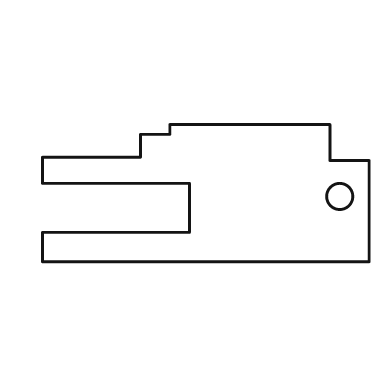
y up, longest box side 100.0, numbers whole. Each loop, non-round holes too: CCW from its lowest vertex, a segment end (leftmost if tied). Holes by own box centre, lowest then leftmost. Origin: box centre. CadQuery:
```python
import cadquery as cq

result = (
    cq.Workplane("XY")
    .moveTo(-50.0, -21.0)
    .lineTo(50.0, -21.0)
    .lineTo(50.0, 10.0)
    .lineTo(38.0, 10.0)
    .lineTo(38.0, 21.0)
    .lineTo(-11.0, 21.0)
    .lineTo(-11.0, 18.0)
    .lineTo(-20.0, 18.0)
    .lineTo(-20.0, 11.0)
    .lineTo(-50.0, 11.0)
    .lineTo(-50.0, 3.0)
    .lineTo(-5.0, 3.0)
    .lineTo(-5.0, -12.0)
    .lineTo(-50.0, -12.0)
    .close()
    .moveTo(41.0, -1.0)
    .circle(4.0)
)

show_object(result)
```